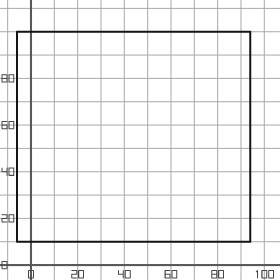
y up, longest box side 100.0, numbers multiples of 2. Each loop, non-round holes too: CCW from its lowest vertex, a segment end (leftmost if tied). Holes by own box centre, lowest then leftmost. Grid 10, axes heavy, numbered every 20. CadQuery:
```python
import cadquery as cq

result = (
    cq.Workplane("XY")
    .moveTo(-6.0, 10.0)
    .lineTo(94.0, 10.0)
    .lineTo(94.0, 100.0)
    .lineTo(-6.0, 100.0)
    .close()
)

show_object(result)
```